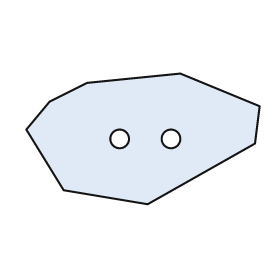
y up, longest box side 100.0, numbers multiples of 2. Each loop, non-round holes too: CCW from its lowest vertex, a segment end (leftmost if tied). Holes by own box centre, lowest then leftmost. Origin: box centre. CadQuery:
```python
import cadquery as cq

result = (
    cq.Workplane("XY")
    .moveTo(2.0, -28.0)
    .lineTo(48.0, -2.0)
    .lineTo(50.0, 14.0)
    .lineTo(16.0, 28.0)
    .lineTo(-24.0, 24.0)
    .lineTo(-40.0, 16.0)
    .lineTo(-50.0, 4.0)
    .lineTo(-34.0, -22.0)
    .close()
    .moveTo(-10.0, 0.0)
    .circle(4.0)
    .moveTo(12.0, 0.0)
    .circle(4.0)
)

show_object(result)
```